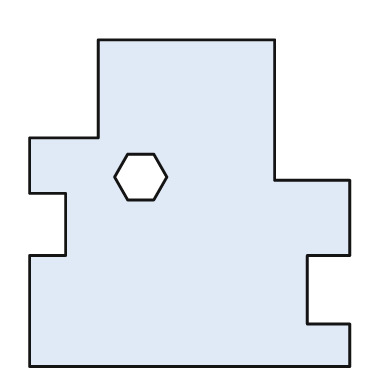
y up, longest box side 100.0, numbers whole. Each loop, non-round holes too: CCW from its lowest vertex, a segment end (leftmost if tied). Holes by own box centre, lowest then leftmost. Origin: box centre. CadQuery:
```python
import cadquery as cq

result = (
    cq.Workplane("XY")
    .moveTo(-49.0, -50.0)
    .lineTo(49.0, -50.0)
    .lineTo(49.0, -37.0)
    .lineTo(36.0, -37.0)
    .lineTo(36.0, -16.0)
    .lineTo(49.0, -16.0)
    .lineTo(49.0, 7.0)
    .lineTo(26.0, 7.0)
    .lineTo(26.0, 50.0)
    .lineTo(-28.0, 50.0)
    .lineTo(-28.0, 20.0)
    .lineTo(-49.0, 20.0)
    .lineTo(-49.0, 3.0)
    .lineTo(-38.0, 3.0)
    .lineTo(-38.0, -16.0)
    .lineTo(-49.0, -16.0)
    .close()
    .moveTo(-19.0, 1.0)
    .lineTo(-11.0, 1.0)
    .lineTo(-7.0, 8.0)
    .lineTo(-11.0, 15.0)
    .lineTo(-19.0, 15.0)
    .lineTo(-23.0, 8.0)
    .close()
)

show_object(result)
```